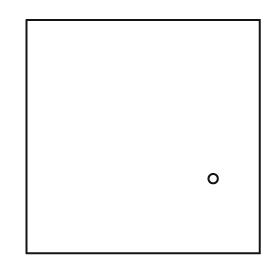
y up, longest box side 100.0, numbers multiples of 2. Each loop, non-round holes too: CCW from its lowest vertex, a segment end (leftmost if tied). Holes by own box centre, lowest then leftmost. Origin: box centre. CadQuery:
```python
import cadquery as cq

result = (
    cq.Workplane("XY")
    .moveTo(-50.0, -50.0)
    .lineTo(50.0, -50.0)
    .lineTo(50.0, 50.0)
    .lineTo(-50.0, 50.0)
    .close()
    .moveTo(30.0, -18.0)
    .circle(2.0)
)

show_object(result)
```